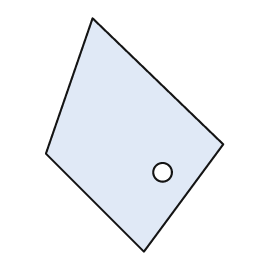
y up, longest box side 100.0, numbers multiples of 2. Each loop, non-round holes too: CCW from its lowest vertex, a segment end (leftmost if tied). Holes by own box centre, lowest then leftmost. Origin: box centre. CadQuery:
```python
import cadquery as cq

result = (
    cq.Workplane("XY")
    .moveTo(4.0, -50.0)
    .lineTo(38.0, -4.0)
    .lineTo(-18.0, 50.0)
    .lineTo(-38.0, -8.0)
    .close()
    .moveTo(12.0, -16.0)
    .circle(4.0)
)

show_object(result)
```